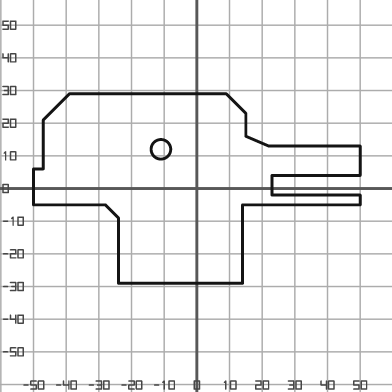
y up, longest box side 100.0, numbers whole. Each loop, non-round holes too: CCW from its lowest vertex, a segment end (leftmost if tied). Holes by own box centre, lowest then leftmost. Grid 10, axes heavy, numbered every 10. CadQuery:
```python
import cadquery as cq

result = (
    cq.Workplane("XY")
    .moveTo(-24.0, -29.0)
    .lineTo(14.0, -29.0)
    .lineTo(14.0, -5.0)
    .lineTo(50.0, -5.0)
    .lineTo(50.0, -2.0)
    .lineTo(23.0, -2.0)
    .lineTo(23.0, 4.0)
    .lineTo(50.0, 4.0)
    .lineTo(50.0, 13.0)
    .lineTo(22.0, 13.0)
    .lineTo(15.0, 16.0)
    .lineTo(15.0, 23.0)
    .lineTo(9.0, 29.0)
    .lineTo(-39.0, 29.0)
    .lineTo(-47.0, 21.0)
    .lineTo(-47.0, 6.0)
    .lineTo(-50.0, 6.0)
    .lineTo(-50.0, -5.0)
    .lineTo(-28.0, -5.0)
    .lineTo(-24.0, -9.0)
    .close()
    .moveTo(-11.0, 12.0)
    .circle(3.0)
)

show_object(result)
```